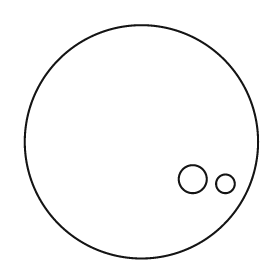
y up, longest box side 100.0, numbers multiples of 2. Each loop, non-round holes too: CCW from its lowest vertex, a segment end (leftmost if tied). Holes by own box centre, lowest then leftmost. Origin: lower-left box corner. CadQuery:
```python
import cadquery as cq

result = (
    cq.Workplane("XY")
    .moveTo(50.0, 50.0)
    .circle(50.0)
    .moveTo(86.0, 32.0)
    .circle(4.0)
    .moveTo(72.0, 34.0)
    .circle(6.0)
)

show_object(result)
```